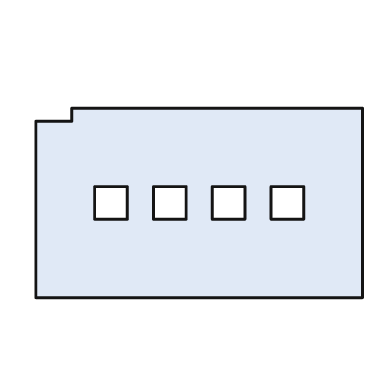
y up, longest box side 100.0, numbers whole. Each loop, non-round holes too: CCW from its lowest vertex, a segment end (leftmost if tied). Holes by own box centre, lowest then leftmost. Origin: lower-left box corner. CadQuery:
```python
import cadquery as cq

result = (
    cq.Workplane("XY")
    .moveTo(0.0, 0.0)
    .lineTo(100.0, 0.0)
    .lineTo(100.0, 58.0)
    .lineTo(11.0, 58.0)
    .lineTo(11.0, 54.0)
    .lineTo(0.0, 54.0)
    .close()
    .moveTo(18.0, 24.0)
    .lineTo(28.0, 24.0)
    .lineTo(28.0, 34.0)
    .lineTo(18.0, 34.0)
    .close()
    .moveTo(36.0, 24.0)
    .lineTo(46.0, 24.0)
    .lineTo(46.0, 34.0)
    .lineTo(36.0, 34.0)
    .close()
    .moveTo(54.0, 24.0)
    .lineTo(64.0, 24.0)
    .lineTo(64.0, 34.0)
    .lineTo(54.0, 34.0)
    .close()
    .moveTo(72.0, 24.0)
    .lineTo(82.0, 24.0)
    .lineTo(82.0, 34.0)
    .lineTo(72.0, 34.0)
    .close()
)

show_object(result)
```